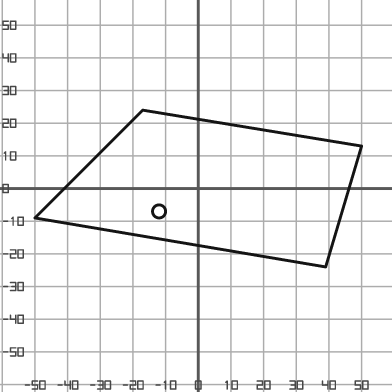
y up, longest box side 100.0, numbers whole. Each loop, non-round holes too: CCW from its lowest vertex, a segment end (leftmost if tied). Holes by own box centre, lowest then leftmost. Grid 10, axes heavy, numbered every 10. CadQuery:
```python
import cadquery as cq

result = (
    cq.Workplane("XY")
    .moveTo(39.0, -24.0)
    .lineTo(50.0, 13.0)
    .lineTo(-17.0, 24.0)
    .lineTo(-50.0, -9.0)
    .close()
    .moveTo(-12.0, -7.0)
    .circle(2.0)
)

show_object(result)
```